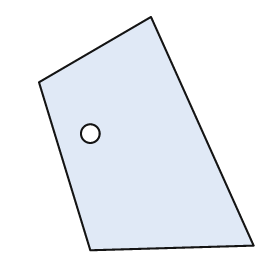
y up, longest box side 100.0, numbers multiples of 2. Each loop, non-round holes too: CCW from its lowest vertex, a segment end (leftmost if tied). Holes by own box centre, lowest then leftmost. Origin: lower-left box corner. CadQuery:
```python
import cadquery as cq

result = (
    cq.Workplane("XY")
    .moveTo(22.0, 0.0)
    .lineTo(92.0, 2.0)
    .lineTo(48.0, 100.0)
    .lineTo(0.0, 72.0)
    .close()
    .moveTo(22.0, 50.0)
    .circle(4.0)
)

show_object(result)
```